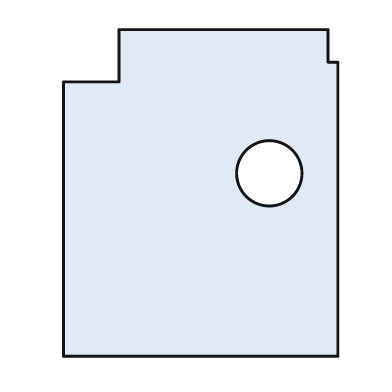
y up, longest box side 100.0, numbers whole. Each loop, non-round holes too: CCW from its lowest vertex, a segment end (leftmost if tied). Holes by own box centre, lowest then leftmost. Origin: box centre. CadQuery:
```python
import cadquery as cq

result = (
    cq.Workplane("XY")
    .moveTo(-42.0, -50.0)
    .lineTo(42.0, -50.0)
    .lineTo(42.0, 40.0)
    .lineTo(39.0, 40.0)
    .lineTo(39.0, 50.0)
    .lineTo(-25.0, 50.0)
    .lineTo(-25.0, 34.0)
    .lineTo(-42.0, 34.0)
    .close()
    .moveTo(21.0, 6.0)
    .circle(10.0)
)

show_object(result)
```